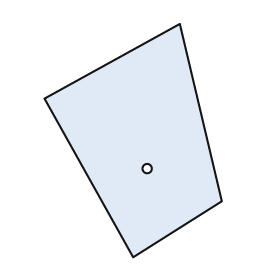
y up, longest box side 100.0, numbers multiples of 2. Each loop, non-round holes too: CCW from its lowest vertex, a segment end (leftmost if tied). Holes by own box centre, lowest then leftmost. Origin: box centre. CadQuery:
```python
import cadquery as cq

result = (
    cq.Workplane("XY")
    .moveTo(0.0, -50.0)
    .lineTo(38.0, -26.0)
    .lineTo(20.0, 50.0)
    .lineTo(-38.0, 18.0)
    .close()
    .moveTo(6.0, -12.0)
    .circle(2.0)
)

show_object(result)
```